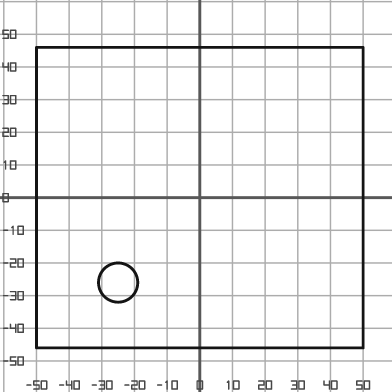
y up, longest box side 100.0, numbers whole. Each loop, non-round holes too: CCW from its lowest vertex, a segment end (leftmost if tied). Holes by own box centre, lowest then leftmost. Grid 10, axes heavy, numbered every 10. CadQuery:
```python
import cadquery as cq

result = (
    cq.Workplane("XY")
    .moveTo(-50.0, -46.0)
    .lineTo(50.0, -46.0)
    .lineTo(50.0, 46.0)
    .lineTo(-50.0, 46.0)
    .close()
    .moveTo(-25.0, -26.0)
    .circle(6.0)
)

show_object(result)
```